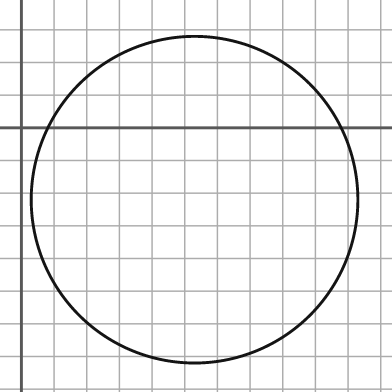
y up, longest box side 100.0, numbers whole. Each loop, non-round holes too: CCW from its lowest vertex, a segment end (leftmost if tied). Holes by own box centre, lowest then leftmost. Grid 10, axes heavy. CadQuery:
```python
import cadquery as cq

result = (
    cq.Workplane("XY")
    .moveTo(53.0, -22.0)
    .circle(50.0)
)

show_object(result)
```